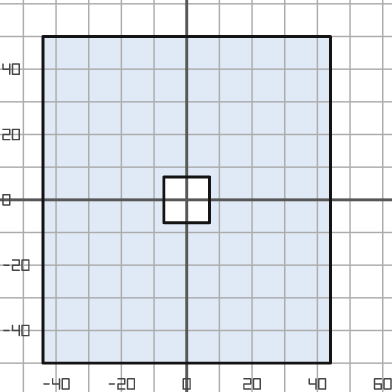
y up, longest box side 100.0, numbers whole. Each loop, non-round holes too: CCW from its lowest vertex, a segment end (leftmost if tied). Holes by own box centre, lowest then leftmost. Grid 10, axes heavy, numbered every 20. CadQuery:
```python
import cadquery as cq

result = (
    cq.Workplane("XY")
    .moveTo(-44.0, -50.0)
    .lineTo(44.0, -50.0)
    .lineTo(44.0, 50.0)
    .lineTo(-44.0, 50.0)
    .close()
    .moveTo(-7.0, -7.0)
    .lineTo(7.0, -7.0)
    .lineTo(7.0, 7.0)
    .lineTo(-7.0, 7.0)
    .close()
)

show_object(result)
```